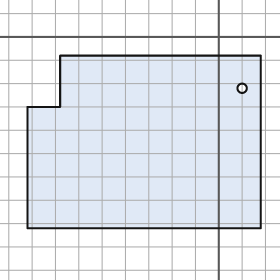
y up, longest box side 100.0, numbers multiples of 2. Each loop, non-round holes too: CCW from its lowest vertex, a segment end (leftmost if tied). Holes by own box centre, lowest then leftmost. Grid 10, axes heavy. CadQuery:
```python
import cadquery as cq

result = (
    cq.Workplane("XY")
    .moveTo(-82.0, -82.0)
    .lineTo(18.0, -82.0)
    .lineTo(18.0, -8.0)
    .lineTo(-68.0, -8.0)
    .lineTo(-68.0, -30.0)
    .lineTo(-82.0, -30.0)
    .close()
    .moveTo(10.0, -22.0)
    .circle(2.0)
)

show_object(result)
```